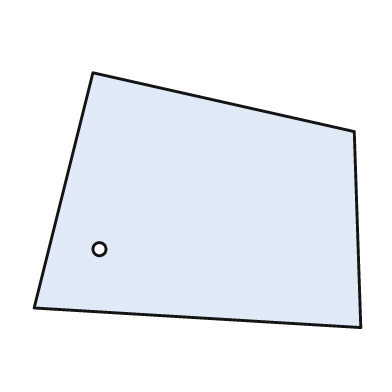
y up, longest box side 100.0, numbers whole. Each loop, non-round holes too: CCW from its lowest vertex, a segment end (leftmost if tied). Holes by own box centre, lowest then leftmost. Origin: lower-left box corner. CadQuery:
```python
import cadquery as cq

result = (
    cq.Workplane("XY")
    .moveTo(100.0, 0.0)
    .lineTo(98.0, 60.0)
    .lineTo(18.0, 78.0)
    .lineTo(0.0, 6.0)
    .close()
    .moveTo(20.0, 24.0)
    .circle(2.0)
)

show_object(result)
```